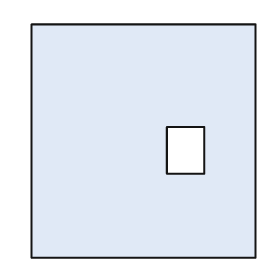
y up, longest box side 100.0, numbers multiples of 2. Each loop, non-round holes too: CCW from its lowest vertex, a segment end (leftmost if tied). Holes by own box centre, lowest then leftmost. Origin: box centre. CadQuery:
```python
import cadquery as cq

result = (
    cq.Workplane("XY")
    .moveTo(-48.0, -50.0)
    .lineTo(48.0, -50.0)
    .lineTo(48.0, 50.0)
    .lineTo(-48.0, 50.0)
    .close()
    .moveTo(10.0, -14.0)
    .lineTo(26.0, -14.0)
    .lineTo(26.0, 6.0)
    .lineTo(10.0, 6.0)
    .close()
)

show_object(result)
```